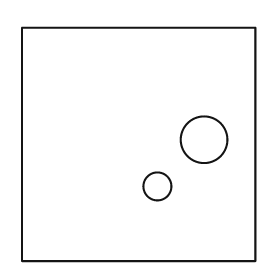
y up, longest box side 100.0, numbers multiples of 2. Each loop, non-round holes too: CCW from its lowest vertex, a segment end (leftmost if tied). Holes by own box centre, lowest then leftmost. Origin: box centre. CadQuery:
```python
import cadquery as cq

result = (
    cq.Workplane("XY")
    .moveTo(-50.0, -50.0)
    .lineTo(50.0, -50.0)
    .lineTo(50.0, 50.0)
    .lineTo(-50.0, 50.0)
    .close()
    .moveTo(8.0, -18.0)
    .circle(6.0)
    .moveTo(28.0, 2.0)
    .circle(10.0)
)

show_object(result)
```